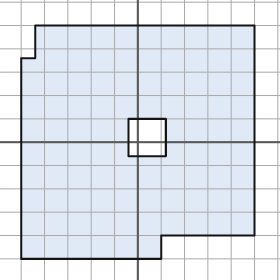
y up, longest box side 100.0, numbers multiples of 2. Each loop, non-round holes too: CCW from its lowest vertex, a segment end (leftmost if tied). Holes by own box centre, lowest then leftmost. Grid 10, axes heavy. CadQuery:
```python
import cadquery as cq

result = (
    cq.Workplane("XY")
    .moveTo(-50.0, -50.0)
    .lineTo(10.0, -50.0)
    .lineTo(10.0, -40.0)
    .lineTo(50.0, -40.0)
    .lineTo(50.0, 50.0)
    .lineTo(-44.0, 50.0)
    .lineTo(-44.0, 36.0)
    .lineTo(-50.0, 36.0)
    .close()
    .moveTo(-4.0, -6.0)
    .lineTo(12.0, -6.0)
    .lineTo(12.0, 10.0)
    .lineTo(-4.0, 10.0)
    .close()
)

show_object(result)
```